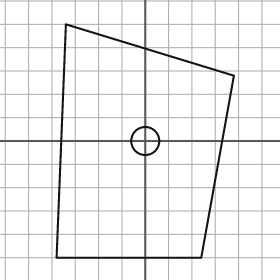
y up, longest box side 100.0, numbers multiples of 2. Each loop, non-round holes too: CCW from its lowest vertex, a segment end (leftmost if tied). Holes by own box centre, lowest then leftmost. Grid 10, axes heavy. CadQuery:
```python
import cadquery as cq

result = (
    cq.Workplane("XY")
    .moveTo(-38.0, -50.0)
    .lineTo(24.0, -50.0)
    .lineTo(38.0, 28.0)
    .lineTo(-34.0, 50.0)
    .close()
    .moveTo(0.0, 0.0)
    .circle(6.0)
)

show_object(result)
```